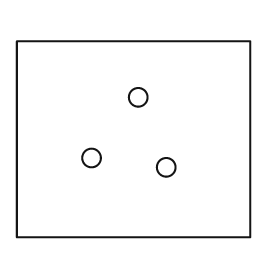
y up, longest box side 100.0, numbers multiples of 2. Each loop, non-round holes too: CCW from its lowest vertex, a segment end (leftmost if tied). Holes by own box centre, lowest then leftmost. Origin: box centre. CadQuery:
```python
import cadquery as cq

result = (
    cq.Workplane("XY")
    .moveTo(-50.0, -42.0)
    .lineTo(50.0, -42.0)
    .lineTo(50.0, 42.0)
    .lineTo(-50.0, 42.0)
    .close()
    .moveTo(14.0, -12.0)
    .circle(4.0)
    .moveTo(-18.0, -8.0)
    .circle(4.0)
    .moveTo(2.0, 18.0)
    .circle(4.0)
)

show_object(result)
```